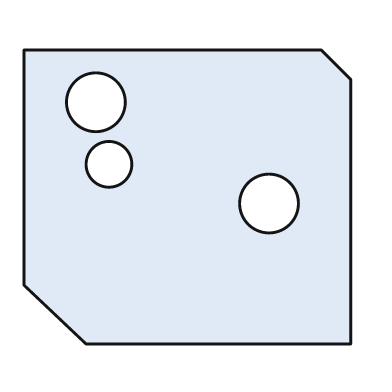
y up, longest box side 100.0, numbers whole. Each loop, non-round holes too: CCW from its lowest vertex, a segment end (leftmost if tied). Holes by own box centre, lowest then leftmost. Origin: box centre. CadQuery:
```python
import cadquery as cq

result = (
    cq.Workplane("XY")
    .moveTo(-31.0, -45.0)
    .lineTo(50.0, -45.0)
    .lineTo(50.0, 36.0)
    .lineTo(41.0, 45.0)
    .lineTo(-50.0, 45.0)
    .lineTo(-50.0, -27.0)
    .close()
    .moveTo(25.0, -2.0)
    .circle(9.0)
    .moveTo(-24.0, 10.0)
    .circle(7.0)
    .moveTo(-28.0, 29.0)
    .circle(9.0)
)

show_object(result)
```